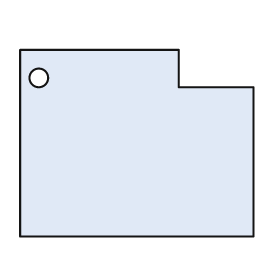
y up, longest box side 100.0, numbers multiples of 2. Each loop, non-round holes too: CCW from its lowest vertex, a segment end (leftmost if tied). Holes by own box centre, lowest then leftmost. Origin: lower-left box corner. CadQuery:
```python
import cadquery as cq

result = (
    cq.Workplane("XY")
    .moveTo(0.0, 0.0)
    .lineTo(100.0, 0.0)
    .lineTo(100.0, 64.0)
    .lineTo(68.0, 64.0)
    .lineTo(68.0, 80.0)
    .lineTo(0.0, 80.0)
    .close()
    .moveTo(8.0, 68.0)
    .circle(4.0)
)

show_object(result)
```